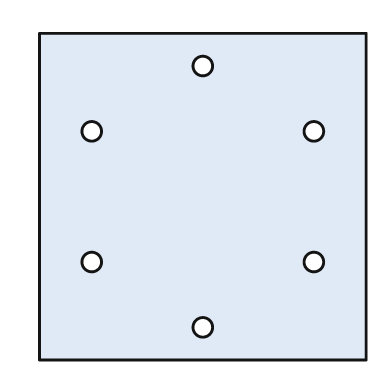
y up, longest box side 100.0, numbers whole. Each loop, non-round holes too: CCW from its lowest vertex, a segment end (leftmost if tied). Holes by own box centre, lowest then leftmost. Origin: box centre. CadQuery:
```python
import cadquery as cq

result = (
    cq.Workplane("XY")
    .moveTo(-50.0, -50.0)
    .lineTo(50.0, -50.0)
    .lineTo(50.0, 50.0)
    .lineTo(-50.0, 50.0)
    .close()
    .moveTo(0.0, -40.0)
    .circle(3.0)
    .moveTo(-34.0, -20.0)
    .circle(3.0)
    .moveTo(34.0, -20.0)
    .circle(3.0)
    .moveTo(-34.0, 20.0)
    .circle(3.0)
    .moveTo(34.0, 20.0)
    .circle(3.0)
    .moveTo(0.0, 40.0)
    .circle(3.0)
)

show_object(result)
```